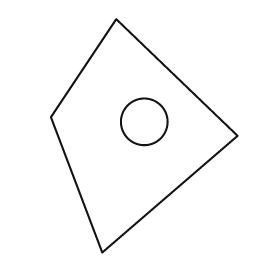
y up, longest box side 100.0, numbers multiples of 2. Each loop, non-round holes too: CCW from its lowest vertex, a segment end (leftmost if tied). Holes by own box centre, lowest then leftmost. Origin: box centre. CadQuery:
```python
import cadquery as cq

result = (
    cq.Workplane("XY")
    .moveTo(-18.0, -50.0)
    .lineTo(40.0, 0.0)
    .lineTo(-12.0, 50.0)
    .lineTo(-40.0, 8.0)
    .close()
    .moveTo(0.0, 6.0)
    .circle(10.0)
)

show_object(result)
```